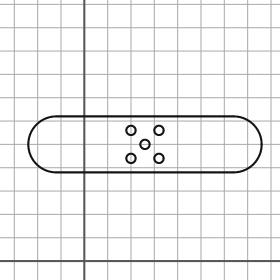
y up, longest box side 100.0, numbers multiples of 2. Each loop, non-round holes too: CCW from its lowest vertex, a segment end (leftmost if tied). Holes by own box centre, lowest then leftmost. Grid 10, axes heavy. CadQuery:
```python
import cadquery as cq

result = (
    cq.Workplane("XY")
    .moveTo(-12.0, 38.0)
    .lineTo(64.0, 38.0)
    .threePointArc((76.0, 50.0), (64.0, 62.0))
    .lineTo(-12.0, 62.0)
    .threePointArc((-24.0, 50.0), (-12.0, 38.0))
    .close()
    .moveTo(20.0, 44.0)
    .circle(2.0)
    .moveTo(32.0, 44.0)
    .circle(2.0)
    .moveTo(26.0, 50.0)
    .circle(2.0)
    .moveTo(20.0, 56.0)
    .circle(2.0)
    .moveTo(32.0, 56.0)
    .circle(2.0)
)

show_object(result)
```